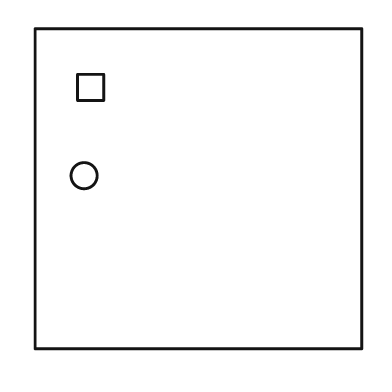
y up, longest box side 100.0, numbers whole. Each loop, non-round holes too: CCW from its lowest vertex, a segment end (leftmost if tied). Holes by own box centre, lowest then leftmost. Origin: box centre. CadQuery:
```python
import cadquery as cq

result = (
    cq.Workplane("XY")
    .moveTo(-50.0, -49.0)
    .lineTo(50.0, -49.0)
    .lineTo(50.0, 49.0)
    .lineTo(-50.0, 49.0)
    .close()
    .moveTo(-35.0, 4.0)
    .circle(4.0)
    .moveTo(-37.0, 27.0)
    .lineTo(-29.0, 27.0)
    .lineTo(-29.0, 35.0)
    .lineTo(-37.0, 35.0)
    .close()
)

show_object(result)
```